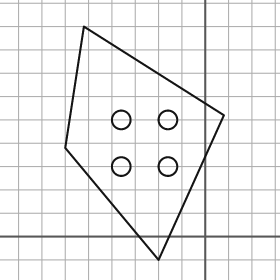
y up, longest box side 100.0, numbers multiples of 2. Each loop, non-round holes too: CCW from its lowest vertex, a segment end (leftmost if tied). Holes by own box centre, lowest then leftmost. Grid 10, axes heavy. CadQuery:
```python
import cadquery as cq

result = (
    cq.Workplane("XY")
    .moveTo(-20.0, -10.0)
    .lineTo(8.0, 52.0)
    .lineTo(-52.0, 90.0)
    .lineTo(-60.0, 38.0)
    .close()
    .moveTo(-36.0, 30.0)
    .circle(4.0)
    .moveTo(-16.0, 30.0)
    .circle(4.0)
    .moveTo(-36.0, 50.0)
    .circle(4.0)
    .moveTo(-16.0, 50.0)
    .circle(4.0)
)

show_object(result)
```